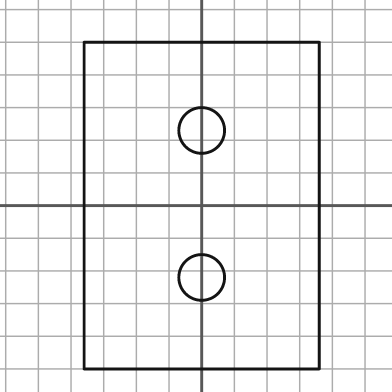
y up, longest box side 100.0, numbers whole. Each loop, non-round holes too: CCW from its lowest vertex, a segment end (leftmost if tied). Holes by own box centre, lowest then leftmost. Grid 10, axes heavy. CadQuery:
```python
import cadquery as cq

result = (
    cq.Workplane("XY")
    .moveTo(-36.0, -50.0)
    .lineTo(36.0, -50.0)
    .lineTo(36.0, 50.0)
    .lineTo(-36.0, 50.0)
    .close()
    .moveTo(0.0, -22.0)
    .circle(7.0)
    .moveTo(0.0, 23.0)
    .circle(7.0)
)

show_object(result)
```